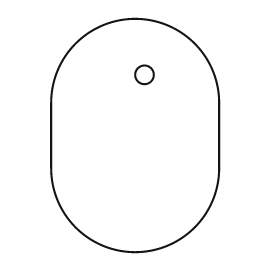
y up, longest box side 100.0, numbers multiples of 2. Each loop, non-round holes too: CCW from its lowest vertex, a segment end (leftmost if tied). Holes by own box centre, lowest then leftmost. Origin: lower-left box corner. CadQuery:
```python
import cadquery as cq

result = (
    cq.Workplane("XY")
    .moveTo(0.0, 36.0)
    .threePointArc((36.0, 0.0), (72.0, 36.0))
    .lineTo(72.0, 64.0)
    .threePointArc((36.0, 100.0), (0.0, 64.0))
    .close()
    .moveTo(40.0, 76.0)
    .circle(4.0)
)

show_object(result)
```